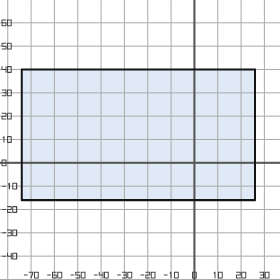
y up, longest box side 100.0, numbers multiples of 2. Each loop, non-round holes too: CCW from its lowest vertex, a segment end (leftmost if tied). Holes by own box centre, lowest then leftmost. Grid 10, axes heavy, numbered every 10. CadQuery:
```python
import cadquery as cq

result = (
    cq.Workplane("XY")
    .moveTo(-74.0, -16.0)
    .lineTo(26.0, -16.0)
    .lineTo(26.0, 40.0)
    .lineTo(-74.0, 40.0)
    .close()
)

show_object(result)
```